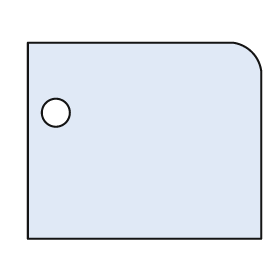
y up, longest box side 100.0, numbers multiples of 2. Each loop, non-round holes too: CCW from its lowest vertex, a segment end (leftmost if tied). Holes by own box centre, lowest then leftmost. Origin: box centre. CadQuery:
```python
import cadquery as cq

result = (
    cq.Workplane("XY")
    .moveTo(-50.0, -42.0)
    .lineTo(50.0, -42.0)
    .lineTo(50.0, 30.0)
    .threePointArc((46.0, 38.0), (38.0, 42.0))
    .lineTo(-50.0, 42.0)
    .close()
    .moveTo(-38.0, 12.0)
    .circle(6.0)
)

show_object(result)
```